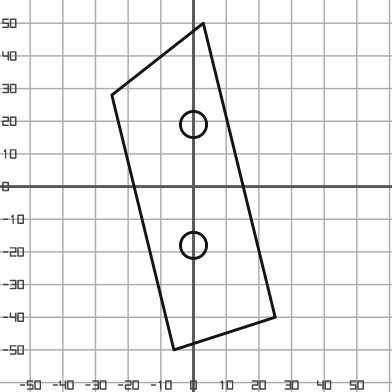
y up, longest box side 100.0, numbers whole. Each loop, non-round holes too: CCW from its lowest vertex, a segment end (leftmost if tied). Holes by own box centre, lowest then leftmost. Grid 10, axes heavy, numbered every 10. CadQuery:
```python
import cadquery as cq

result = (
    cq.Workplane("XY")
    .moveTo(-6.0, -50.0)
    .lineTo(25.0, -40.0)
    .lineTo(3.0, 50.0)
    .lineTo(-25.0, 28.0)
    .close()
    .moveTo(0.0, -18.0)
    .circle(4.0)
    .moveTo(0.0, 19.0)
    .circle(4.0)
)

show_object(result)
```